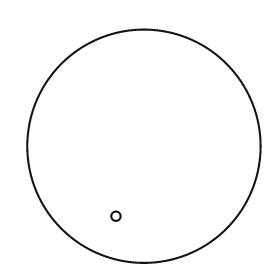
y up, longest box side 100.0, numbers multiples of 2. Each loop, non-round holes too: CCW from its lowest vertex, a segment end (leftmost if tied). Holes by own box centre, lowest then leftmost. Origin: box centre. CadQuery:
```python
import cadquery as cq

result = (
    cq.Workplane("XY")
    .moveTo(0.0, 0.0)
    .circle(50.0)
    .moveTo(-12.0, -30.0)
    .circle(2.0)
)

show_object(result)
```